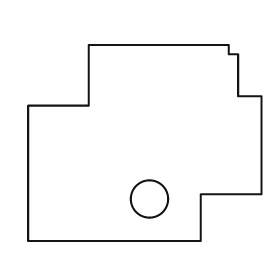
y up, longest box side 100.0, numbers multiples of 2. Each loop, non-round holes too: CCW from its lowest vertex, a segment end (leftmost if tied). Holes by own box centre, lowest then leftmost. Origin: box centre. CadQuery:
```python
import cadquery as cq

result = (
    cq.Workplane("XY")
    .moveTo(-50.0, -42.0)
    .lineTo(24.0, -42.0)
    .lineTo(24.0, -22.0)
    .lineTo(50.0, -22.0)
    .lineTo(50.0, 20.0)
    .lineTo(40.0, 20.0)
    .lineTo(40.0, 38.0)
    .lineTo(36.0, 38.0)
    .lineTo(36.0, 42.0)
    .lineTo(-24.0, 42.0)
    .lineTo(-24.0, 16.0)
    .lineTo(-50.0, 16.0)
    .close()
    .moveTo(2.0, -24.0)
    .circle(8.0)
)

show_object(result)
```